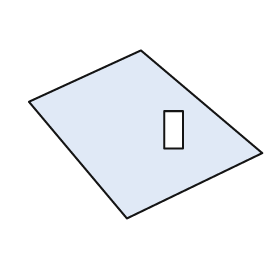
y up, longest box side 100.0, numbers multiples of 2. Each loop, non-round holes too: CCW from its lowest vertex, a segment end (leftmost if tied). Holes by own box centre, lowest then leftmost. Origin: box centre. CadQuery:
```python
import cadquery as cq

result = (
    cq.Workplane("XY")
    .moveTo(-8.0, -36.0)
    .lineTo(50.0, -8.0)
    .lineTo(-2.0, 36.0)
    .lineTo(-50.0, 14.0)
    .close()
    .moveTo(8.0, -6.0)
    .lineTo(16.0, -6.0)
    .lineTo(16.0, 10.0)
    .lineTo(8.0, 10.0)
    .close()
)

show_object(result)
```